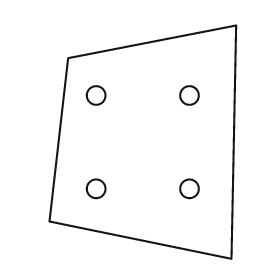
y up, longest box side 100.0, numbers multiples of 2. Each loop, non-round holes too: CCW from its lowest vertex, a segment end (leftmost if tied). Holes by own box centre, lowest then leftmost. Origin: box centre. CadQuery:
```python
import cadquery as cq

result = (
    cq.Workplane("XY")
    .moveTo(38.0, -50.0)
    .lineTo(40.0, 50.0)
    .lineTo(-32.0, 36.0)
    .lineTo(-40.0, -34.0)
    .close()
    .moveTo(-20.0, -20.0)
    .circle(4.0)
    .moveTo(20.0, -20.0)
    .circle(4.0)
    .moveTo(-20.0, 20.0)
    .circle(4.0)
    .moveTo(20.0, 20.0)
    .circle(4.0)
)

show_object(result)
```